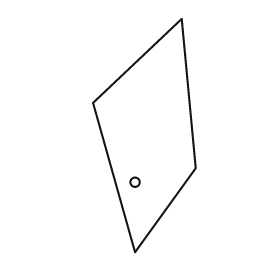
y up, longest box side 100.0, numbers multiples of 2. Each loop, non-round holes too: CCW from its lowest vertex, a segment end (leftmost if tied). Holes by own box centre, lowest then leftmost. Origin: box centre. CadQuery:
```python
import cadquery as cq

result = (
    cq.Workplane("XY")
    .moveTo(-4.0, -50.0)
    .lineTo(22.0, -14.0)
    .lineTo(16.0, 50.0)
    .lineTo(-22.0, 14.0)
    .close()
    .moveTo(-4.0, -20.0)
    .circle(2.0)
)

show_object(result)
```